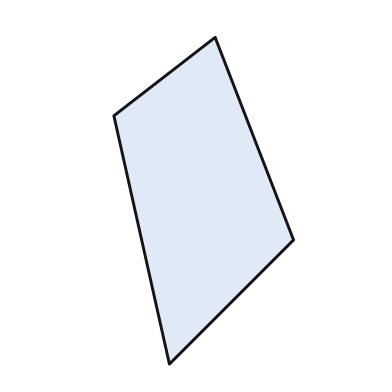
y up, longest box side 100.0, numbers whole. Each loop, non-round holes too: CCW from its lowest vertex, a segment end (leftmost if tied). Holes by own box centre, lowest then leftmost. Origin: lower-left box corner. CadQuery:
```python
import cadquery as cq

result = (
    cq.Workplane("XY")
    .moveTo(17.0, 0.0)
    .lineTo(55.0, 38.0)
    .lineTo(31.0, 100.0)
    .lineTo(0.0, 76.0)
    .close()
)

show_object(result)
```